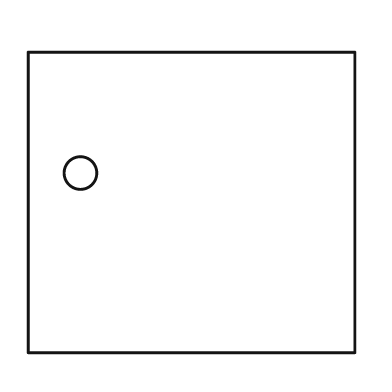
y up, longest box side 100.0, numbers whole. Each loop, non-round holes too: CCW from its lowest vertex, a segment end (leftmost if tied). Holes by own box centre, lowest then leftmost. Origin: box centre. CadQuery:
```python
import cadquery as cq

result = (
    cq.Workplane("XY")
    .moveTo(-50.0, -46.0)
    .lineTo(50.0, -46.0)
    .lineTo(50.0, 46.0)
    .lineTo(-50.0, 46.0)
    .close()
    .moveTo(-34.0, 9.0)
    .circle(5.0)
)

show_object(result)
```